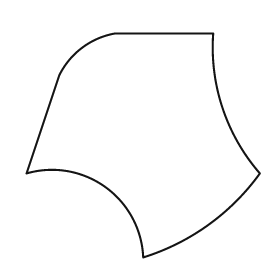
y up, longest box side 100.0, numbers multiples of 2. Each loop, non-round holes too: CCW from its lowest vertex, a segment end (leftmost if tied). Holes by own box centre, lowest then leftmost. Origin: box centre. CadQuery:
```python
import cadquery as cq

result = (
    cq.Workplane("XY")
    .moveTo(0.0, -48.0)
    .threePointArc((28.0, -34.0), (50.0, -12.0))
    .threePointArc((34.0, 16.0), (30.0, 48.0))
    .lineTo(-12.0, 48.0)
    .threePointArc((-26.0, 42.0), (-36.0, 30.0))
    .lineTo(-50.0, -12.0)
    .threePointArc((-16.0, -18.0), (0.0, -48.0))
    .close()
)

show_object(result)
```